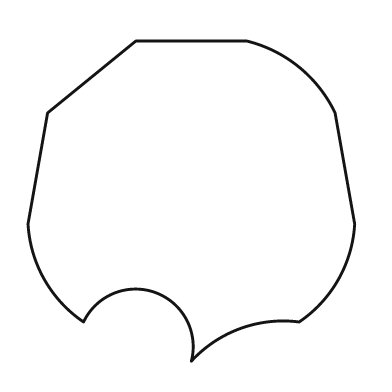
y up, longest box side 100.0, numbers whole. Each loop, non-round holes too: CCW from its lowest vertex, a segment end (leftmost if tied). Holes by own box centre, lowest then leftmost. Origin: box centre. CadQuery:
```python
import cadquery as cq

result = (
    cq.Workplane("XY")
    .moveTo(0.0, -49.0)
    .threePointArc((15.0, -39.0), (33.0, -37.0))
    .threePointArc((45.0, -24.0), (50.0, -7.0))
    .lineTo(44.0, 27.0)
    .threePointArc((33.0, 41.0), (17.0, 49.0))
    .lineTo(-17.0, 49.0)
    .lineTo(-44.0, 27.0)
    .lineTo(-50.0, -7.0)
    .threePointArc((-45.0, -24.0), (-33.0, -37.0))
    .threePointArc((-11.0, -28.0), (0.0, -49.0))
    .close()
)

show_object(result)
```